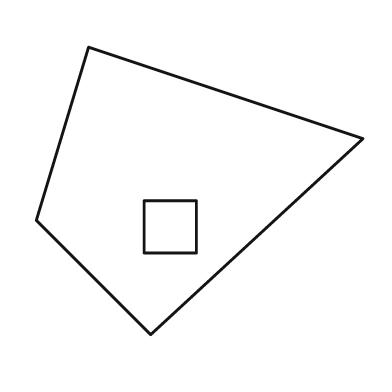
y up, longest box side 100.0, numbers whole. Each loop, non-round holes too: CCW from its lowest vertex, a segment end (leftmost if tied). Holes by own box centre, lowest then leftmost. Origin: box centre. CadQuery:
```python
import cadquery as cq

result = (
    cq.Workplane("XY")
    .moveTo(-15.0, -44.0)
    .lineTo(50.0, 16.0)
    .lineTo(-34.0, 44.0)
    .lineTo(-50.0, -9.0)
    .close()
    .moveTo(-17.0, -19.0)
    .lineTo(-1.0, -19.0)
    .lineTo(-1.0, -3.0)
    .lineTo(-17.0, -3.0)
    .close()
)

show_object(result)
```